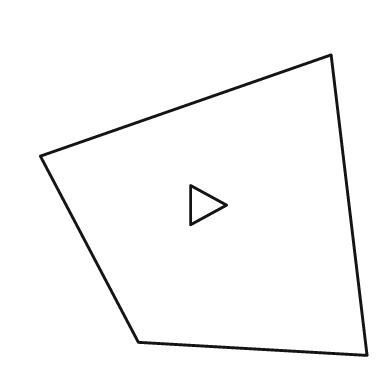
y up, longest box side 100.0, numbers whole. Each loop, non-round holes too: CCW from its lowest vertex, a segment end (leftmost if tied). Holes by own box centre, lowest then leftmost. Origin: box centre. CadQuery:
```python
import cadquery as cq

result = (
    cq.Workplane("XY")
    .moveTo(50.0, -46.0)
    .lineTo(39.0, 46.0)
    .lineTo(-50.0, 15.0)
    .lineTo(-20.0, -42.0)
    .close()
    .moveTo(-4.0, -6.0)
    .lineTo(7.0, 0.0)
    .lineTo(-4.0, 6.0)
    .close()
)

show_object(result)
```